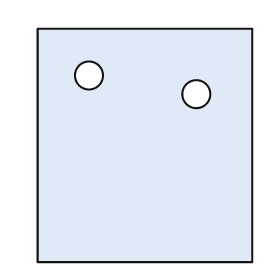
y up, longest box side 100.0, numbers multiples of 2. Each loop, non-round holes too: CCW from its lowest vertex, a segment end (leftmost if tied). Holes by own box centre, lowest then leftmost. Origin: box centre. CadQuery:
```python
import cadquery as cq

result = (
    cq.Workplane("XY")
    .moveTo(-46.0, -50.0)
    .lineTo(46.0, -50.0)
    .lineTo(46.0, 50.0)
    .lineTo(-46.0, 50.0)
    .close()
    .moveTo(22.0, 22.0)
    .circle(6.0)
    .moveTo(-24.0, 30.0)
    .circle(6.0)
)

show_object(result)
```